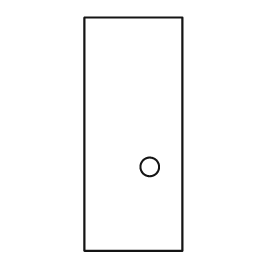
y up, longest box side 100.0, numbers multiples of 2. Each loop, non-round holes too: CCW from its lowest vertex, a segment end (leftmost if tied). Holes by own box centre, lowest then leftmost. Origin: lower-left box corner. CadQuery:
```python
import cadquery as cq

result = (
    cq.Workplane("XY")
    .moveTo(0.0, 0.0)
    .lineTo(42.0, 0.0)
    .lineTo(42.0, 100.0)
    .lineTo(0.0, 100.0)
    .close()
    .moveTo(28.0, 36.0)
    .circle(4.0)
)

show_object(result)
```